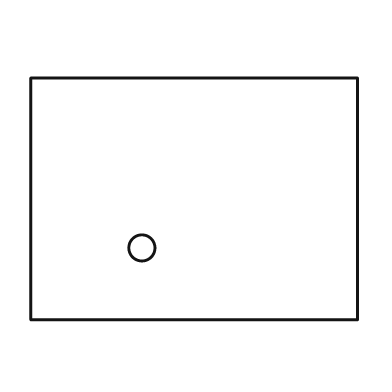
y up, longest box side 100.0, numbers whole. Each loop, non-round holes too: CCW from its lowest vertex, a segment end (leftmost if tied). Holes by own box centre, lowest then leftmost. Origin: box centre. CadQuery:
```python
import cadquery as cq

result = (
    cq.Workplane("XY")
    .moveTo(-50.0, -37.0)
    .lineTo(50.0, -37.0)
    .lineTo(50.0, 37.0)
    .lineTo(-50.0, 37.0)
    .close()
    .moveTo(-16.0, -15.0)
    .circle(4.0)
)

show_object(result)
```